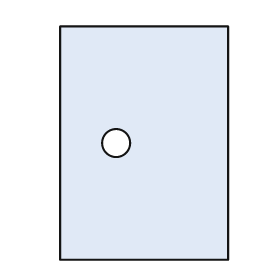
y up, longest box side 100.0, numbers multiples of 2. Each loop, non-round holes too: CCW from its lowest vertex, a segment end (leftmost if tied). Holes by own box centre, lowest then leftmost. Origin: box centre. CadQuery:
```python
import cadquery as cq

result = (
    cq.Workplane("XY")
    .moveTo(-36.0, -50.0)
    .lineTo(36.0, -50.0)
    .lineTo(36.0, 50.0)
    .lineTo(-36.0, 50.0)
    .close()
    .moveTo(-12.0, 0.0)
    .circle(6.0)
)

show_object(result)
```